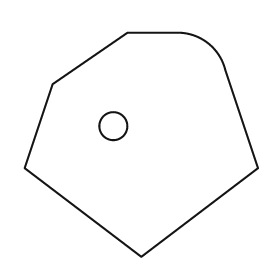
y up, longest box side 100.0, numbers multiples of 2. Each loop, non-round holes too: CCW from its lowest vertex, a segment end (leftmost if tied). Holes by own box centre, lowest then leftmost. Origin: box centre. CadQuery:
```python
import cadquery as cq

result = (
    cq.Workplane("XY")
    .moveTo(0.0, -48.0)
    .lineTo(50.0, -10.0)
    .lineTo(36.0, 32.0)
    .threePointArc((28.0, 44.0), (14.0, 48.0))
    .lineTo(-6.0, 48.0)
    .lineTo(-38.0, 26.0)
    .lineTo(-50.0, -10.0)
    .close()
    .moveTo(-12.0, 8.0)
    .circle(6.0)
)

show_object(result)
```